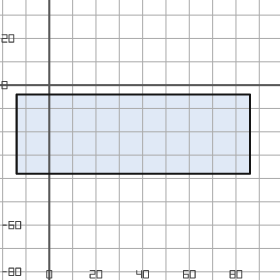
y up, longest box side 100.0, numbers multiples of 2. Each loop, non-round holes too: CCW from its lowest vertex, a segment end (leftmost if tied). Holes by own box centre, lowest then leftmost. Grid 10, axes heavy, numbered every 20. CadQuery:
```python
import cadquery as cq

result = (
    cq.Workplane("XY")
    .moveTo(-14.0, -38.0)
    .lineTo(86.0, -38.0)
    .lineTo(86.0, -4.0)
    .lineTo(-14.0, -4.0)
    .close()
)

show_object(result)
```